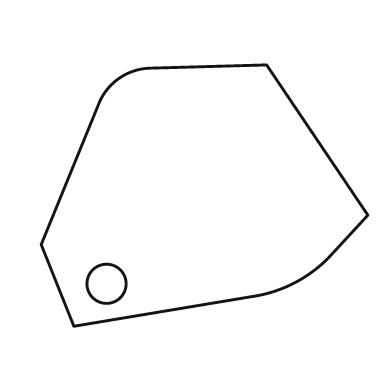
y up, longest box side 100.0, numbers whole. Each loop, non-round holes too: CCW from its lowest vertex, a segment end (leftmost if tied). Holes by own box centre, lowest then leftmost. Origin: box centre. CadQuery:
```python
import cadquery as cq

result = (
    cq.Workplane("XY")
    .moveTo(-40.0, -40.0)
    .lineTo(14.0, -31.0)
    .threePointArc((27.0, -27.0), (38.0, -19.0))
    .lineTo(50.0, -6.0)
    .lineTo(19.0, 40.0)
    .lineTo(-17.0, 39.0)
    .threePointArc((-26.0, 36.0), (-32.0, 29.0))
    .lineTo(-50.0, -15.0)
    .close()
    .moveTo(-30.0, -27.0)
    .circle(6.0)
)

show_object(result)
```